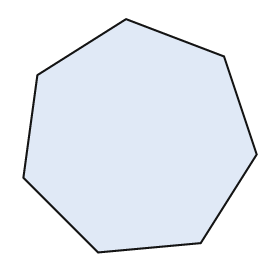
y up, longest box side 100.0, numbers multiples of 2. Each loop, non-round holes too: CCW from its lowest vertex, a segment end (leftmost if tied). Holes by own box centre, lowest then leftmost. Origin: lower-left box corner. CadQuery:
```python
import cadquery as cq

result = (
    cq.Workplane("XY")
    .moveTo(32.0, 0.0)
    .lineTo(76.0, 4.0)
    .lineTo(100.0, 42.0)
    .lineTo(86.0, 84.0)
    .lineTo(44.0, 100.0)
    .lineTo(6.0, 76.0)
    .lineTo(0.0, 32.0)
    .close()
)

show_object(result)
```